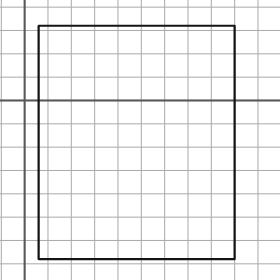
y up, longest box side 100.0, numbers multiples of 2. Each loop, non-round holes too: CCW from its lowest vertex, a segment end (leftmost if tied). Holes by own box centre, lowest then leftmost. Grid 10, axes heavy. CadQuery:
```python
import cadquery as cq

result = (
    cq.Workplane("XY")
    .moveTo(6.0, -68.0)
    .lineTo(90.0, -68.0)
    .lineTo(90.0, 32.0)
    .lineTo(6.0, 32.0)
    .close()
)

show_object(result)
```